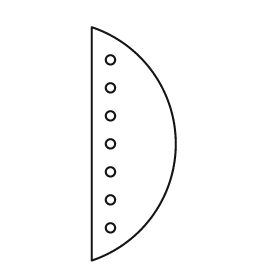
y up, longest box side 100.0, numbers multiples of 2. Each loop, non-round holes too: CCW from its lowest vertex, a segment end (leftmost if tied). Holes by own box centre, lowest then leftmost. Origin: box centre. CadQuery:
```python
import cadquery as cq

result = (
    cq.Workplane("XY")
    .moveTo(-18.0, -50.0)
    .threePointArc((18.0, 0.0), (-18.0, 50.0))
    .close()
    .moveTo(-10.0, -36.0)
    .circle(2.0)
    .moveTo(-10.0, -24.0)
    .circle(2.0)
    .moveTo(-10.0, -12.0)
    .circle(2.0)
    .moveTo(-10.0, 0.0)
    .circle(2.0)
    .moveTo(-10.0, 12.0)
    .circle(2.0)
    .moveTo(-10.0, 24.0)
    .circle(2.0)
    .moveTo(-10.0, 36.0)
    .circle(2.0)
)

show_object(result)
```